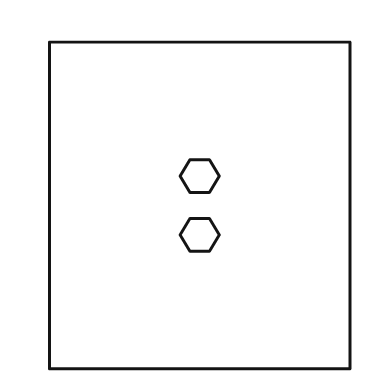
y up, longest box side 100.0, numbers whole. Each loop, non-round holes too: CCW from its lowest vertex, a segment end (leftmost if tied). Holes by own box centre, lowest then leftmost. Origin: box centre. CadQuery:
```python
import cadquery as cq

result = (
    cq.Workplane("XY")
    .moveTo(-46.0, -50.0)
    .lineTo(46.0, -50.0)
    .lineTo(46.0, 50.0)
    .lineTo(-46.0, 50.0)
    .close()
    .moveTo(-3.0, -14.0)
    .lineTo(3.0, -14.0)
    .lineTo(6.0, -9.0)
    .lineTo(3.0, -4.0)
    .lineTo(-3.0, -4.0)
    .lineTo(-6.0, -9.0)
    .close()
    .moveTo(-3.0, 4.0)
    .lineTo(3.0, 4.0)
    .lineTo(6.0, 9.0)
    .lineTo(3.0, 14.0)
    .lineTo(-3.0, 14.0)
    .lineTo(-6.0, 9.0)
    .close()
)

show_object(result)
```